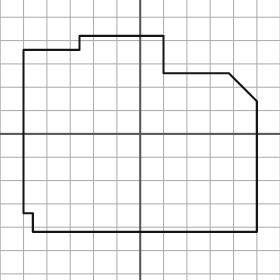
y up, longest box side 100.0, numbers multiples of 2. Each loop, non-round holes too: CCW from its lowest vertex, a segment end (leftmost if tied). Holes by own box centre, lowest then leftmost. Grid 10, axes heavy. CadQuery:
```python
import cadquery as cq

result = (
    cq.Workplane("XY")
    .moveTo(-46.0, -42.0)
    .lineTo(50.0, -42.0)
    .lineTo(50.0, 14.0)
    .lineTo(38.0, 26.0)
    .lineTo(10.0, 26.0)
    .lineTo(10.0, 42.0)
    .lineTo(-26.0, 42.0)
    .lineTo(-26.0, 36.0)
    .lineTo(-50.0, 36.0)
    .lineTo(-50.0, -34.0)
    .lineTo(-46.0, -34.0)
    .close()
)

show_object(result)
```